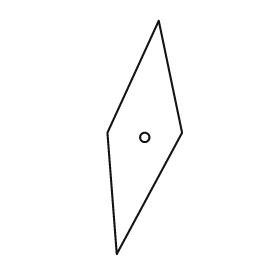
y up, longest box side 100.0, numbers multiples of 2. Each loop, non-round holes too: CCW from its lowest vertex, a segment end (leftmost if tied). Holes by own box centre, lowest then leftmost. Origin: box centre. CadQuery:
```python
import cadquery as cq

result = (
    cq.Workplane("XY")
    .moveTo(-12.0, -50.0)
    .lineTo(16.0, 2.0)
    .lineTo(6.0, 50.0)
    .lineTo(-16.0, 2.0)
    .close()
    .moveTo(0.0, 0.0)
    .circle(2.0)
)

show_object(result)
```